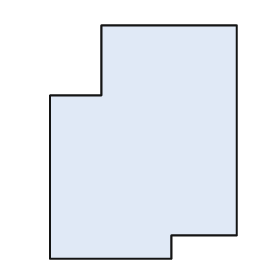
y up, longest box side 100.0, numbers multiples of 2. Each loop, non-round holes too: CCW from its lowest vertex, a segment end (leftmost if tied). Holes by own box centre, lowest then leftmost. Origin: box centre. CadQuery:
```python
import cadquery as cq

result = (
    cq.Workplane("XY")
    .moveTo(-40.0, -50.0)
    .lineTo(12.0, -50.0)
    .lineTo(12.0, -40.0)
    .lineTo(40.0, -40.0)
    .lineTo(40.0, 50.0)
    .lineTo(-18.0, 50.0)
    .lineTo(-18.0, 20.0)
    .lineTo(-40.0, 20.0)
    .close()
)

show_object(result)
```